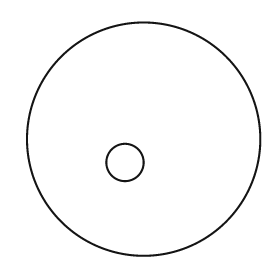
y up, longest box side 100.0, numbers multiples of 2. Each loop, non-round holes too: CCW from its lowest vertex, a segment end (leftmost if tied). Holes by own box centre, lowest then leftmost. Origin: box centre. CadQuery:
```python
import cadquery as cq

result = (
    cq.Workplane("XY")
    .moveTo(0.0, 0.0)
    .circle(50.0)
    .moveTo(-8.0, -10.0)
    .circle(8.0)
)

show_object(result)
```